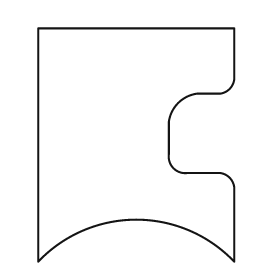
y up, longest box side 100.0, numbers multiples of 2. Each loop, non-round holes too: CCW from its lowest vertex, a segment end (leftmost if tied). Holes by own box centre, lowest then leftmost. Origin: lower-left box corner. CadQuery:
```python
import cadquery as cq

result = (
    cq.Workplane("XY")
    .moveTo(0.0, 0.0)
    .threePointArc((42.0, 18.0), (84.0, 0.0))
    .lineTo(84.0, 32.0)
    .threePointArc((82.0, 36.0), (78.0, 38.0))
    .lineTo(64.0, 38.0)
    .threePointArc((58.0, 40.0), (56.0, 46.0))
    .lineTo(56.0, 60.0)
    .threePointArc((60.0, 68.0), (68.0, 72.0))
    .lineTo(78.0, 72.0)
    .threePointArc((82.0, 74.0), (84.0, 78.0))
    .lineTo(84.0, 100.0)
    .lineTo(0.0, 100.0)
    .close()
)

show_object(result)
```